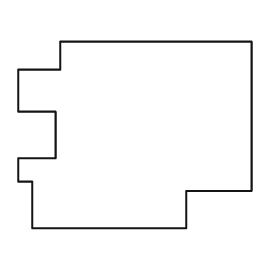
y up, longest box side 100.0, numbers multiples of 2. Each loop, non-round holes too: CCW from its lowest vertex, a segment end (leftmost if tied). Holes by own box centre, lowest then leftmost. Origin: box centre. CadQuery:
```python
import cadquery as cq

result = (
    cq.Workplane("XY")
    .moveTo(-44.0, -40.0)
    .lineTo(22.0, -40.0)
    .lineTo(22.0, -24.0)
    .lineTo(50.0, -24.0)
    .lineTo(50.0, 40.0)
    .lineTo(-32.0, 40.0)
    .lineTo(-32.0, 28.0)
    .lineTo(-50.0, 28.0)
    .lineTo(-50.0, 10.0)
    .lineTo(-34.0, 10.0)
    .lineTo(-34.0, -10.0)
    .lineTo(-50.0, -10.0)
    .lineTo(-50.0, -20.0)
    .lineTo(-44.0, -20.0)
    .close()
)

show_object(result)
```